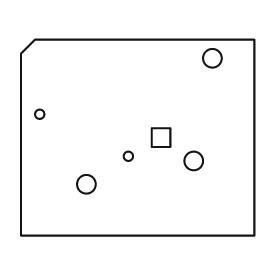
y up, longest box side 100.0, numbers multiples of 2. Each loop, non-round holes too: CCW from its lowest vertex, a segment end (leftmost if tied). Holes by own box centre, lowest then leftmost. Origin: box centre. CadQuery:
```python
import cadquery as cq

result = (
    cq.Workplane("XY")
    .moveTo(-50.0, -42.0)
    .lineTo(50.0, -42.0)
    .lineTo(50.0, 42.0)
    .lineTo(-44.0, 42.0)
    .lineTo(-50.0, 36.0)
    .close()
    .moveTo(-22.0, -20.0)
    .circle(4.0)
    .moveTo(24.0, -10.0)
    .circle(4.0)
    .moveTo(-4.0, -8.0)
    .circle(2.0)
    .moveTo(6.0, -4.0)
    .lineTo(14.0, -4.0)
    .lineTo(14.0, 4.0)
    .lineTo(6.0, 4.0)
    .close()
    .moveTo(-42.0, 10.0)
    .circle(2.0)
    .moveTo(32.0, 34.0)
    .circle(4.0)
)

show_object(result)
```